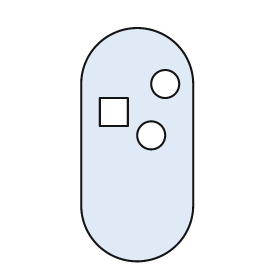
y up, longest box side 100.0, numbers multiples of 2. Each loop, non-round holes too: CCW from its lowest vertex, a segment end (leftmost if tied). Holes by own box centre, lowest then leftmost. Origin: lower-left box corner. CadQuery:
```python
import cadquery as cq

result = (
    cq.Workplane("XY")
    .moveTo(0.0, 24.0)
    .threePointArc((24.0, 0.0), (48.0, 24.0))
    .lineTo(48.0, 76.0)
    .threePointArc((24.0, 100.0), (0.0, 76.0))
    .close()
    .moveTo(30.0, 54.0)
    .circle(6.0)
    .moveTo(8.0, 58.0)
    .lineTo(20.0, 58.0)
    .lineTo(20.0, 70.0)
    .lineTo(8.0, 70.0)
    .close()
    .moveTo(36.0, 76.0)
    .circle(6.0)
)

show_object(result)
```